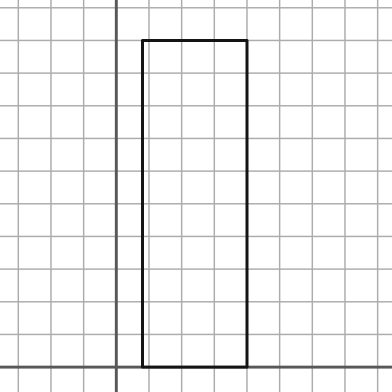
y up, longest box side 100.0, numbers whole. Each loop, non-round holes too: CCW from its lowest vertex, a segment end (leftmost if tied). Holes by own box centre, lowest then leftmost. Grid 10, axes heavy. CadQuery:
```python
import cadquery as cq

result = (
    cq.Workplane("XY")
    .moveTo(8.0, 0.0)
    .lineTo(40.0, 0.0)
    .lineTo(40.0, 100.0)
    .lineTo(8.0, 100.0)
    .close()
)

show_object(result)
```